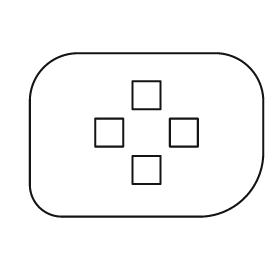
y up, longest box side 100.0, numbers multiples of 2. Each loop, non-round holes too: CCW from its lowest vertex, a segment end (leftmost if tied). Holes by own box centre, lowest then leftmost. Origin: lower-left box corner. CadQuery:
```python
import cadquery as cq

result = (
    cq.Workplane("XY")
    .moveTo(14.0, 0.0)
    .lineTo(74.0, 0.0)
    .threePointArc((92.0, 8.0), (100.0, 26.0))
    .lineTo(100.0, 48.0)
    .threePointArc((94.0, 64.0), (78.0, 70.0))
    .lineTo(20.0, 70.0)
    .threePointArc((6.0, 64.0), (0.0, 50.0))
    .lineTo(0.0, 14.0)
    .threePointArc((4.0, 4.0), (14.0, 0.0))
    .close()
    .moveTo(44.0, 14.0)
    .lineTo(56.0, 14.0)
    .lineTo(56.0, 26.0)
    .lineTo(44.0, 26.0)
    .close()
    .moveTo(28.0, 30.0)
    .lineTo(40.0, 30.0)
    .lineTo(40.0, 42.0)
    .lineTo(28.0, 42.0)
    .close()
    .moveTo(60.0, 30.0)
    .lineTo(72.0, 30.0)
    .lineTo(72.0, 42.0)
    .lineTo(60.0, 42.0)
    .close()
    .moveTo(44.0, 46.0)
    .lineTo(56.0, 46.0)
    .lineTo(56.0, 58.0)
    .lineTo(44.0, 58.0)
    .close()
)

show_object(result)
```